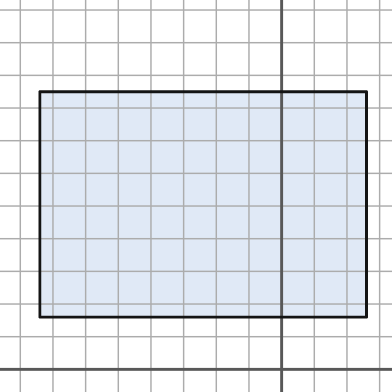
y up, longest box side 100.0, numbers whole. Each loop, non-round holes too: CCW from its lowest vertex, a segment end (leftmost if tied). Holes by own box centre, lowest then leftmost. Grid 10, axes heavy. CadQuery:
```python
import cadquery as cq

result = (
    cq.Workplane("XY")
    .moveTo(-74.0, 16.0)
    .lineTo(26.0, 16.0)
    .lineTo(26.0, 85.0)
    .lineTo(-74.0, 85.0)
    .close()
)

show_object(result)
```